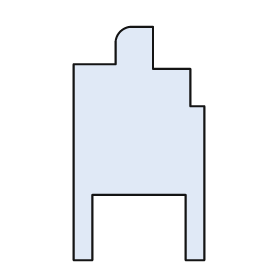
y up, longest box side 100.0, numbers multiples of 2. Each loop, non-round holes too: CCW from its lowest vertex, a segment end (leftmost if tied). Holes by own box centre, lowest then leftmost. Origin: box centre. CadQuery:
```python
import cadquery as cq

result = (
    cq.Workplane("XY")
    .moveTo(-28.0, -50.0)
    .lineTo(-20.0, -50.0)
    .lineTo(-20.0, -22.0)
    .lineTo(20.0, -22.0)
    .lineTo(20.0, -50.0)
    .lineTo(28.0, -50.0)
    .lineTo(28.0, 16.0)
    .lineTo(22.0, 16.0)
    .lineTo(22.0, 32.0)
    .lineTo(6.0, 32.0)
    .lineTo(6.0, 50.0)
    .lineTo(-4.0, 50.0)
    .threePointArc((-8.0, 48.0), (-10.0, 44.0))
    .lineTo(-10.0, 34.0)
    .lineTo(-28.0, 34.0)
    .close()
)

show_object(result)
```